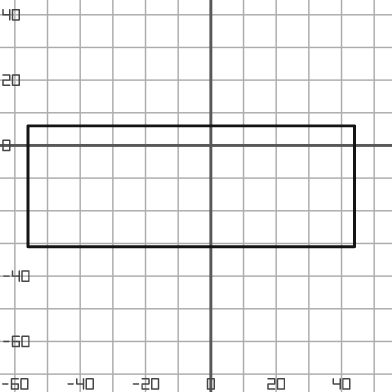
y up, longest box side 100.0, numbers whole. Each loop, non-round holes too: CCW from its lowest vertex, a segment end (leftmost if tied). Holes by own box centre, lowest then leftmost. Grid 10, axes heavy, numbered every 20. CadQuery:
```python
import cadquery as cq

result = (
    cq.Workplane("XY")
    .moveTo(-56.0, -31.0)
    .lineTo(44.0, -31.0)
    .lineTo(44.0, 6.0)
    .lineTo(-56.0, 6.0)
    .close()
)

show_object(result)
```